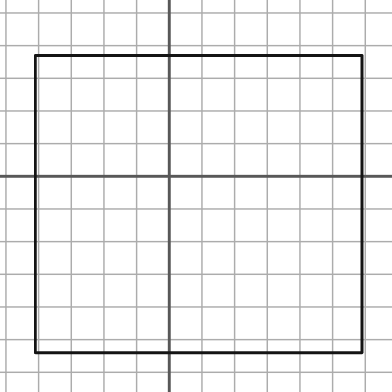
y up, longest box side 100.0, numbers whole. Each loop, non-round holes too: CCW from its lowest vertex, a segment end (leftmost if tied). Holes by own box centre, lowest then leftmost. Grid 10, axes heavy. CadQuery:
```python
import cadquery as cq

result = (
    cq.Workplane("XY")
    .moveTo(-41.0, -54.0)
    .lineTo(59.0, -54.0)
    .lineTo(59.0, 37.0)
    .lineTo(-41.0, 37.0)
    .close()
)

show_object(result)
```